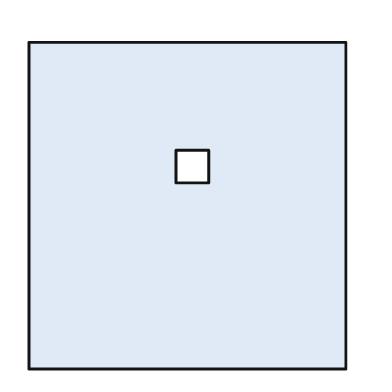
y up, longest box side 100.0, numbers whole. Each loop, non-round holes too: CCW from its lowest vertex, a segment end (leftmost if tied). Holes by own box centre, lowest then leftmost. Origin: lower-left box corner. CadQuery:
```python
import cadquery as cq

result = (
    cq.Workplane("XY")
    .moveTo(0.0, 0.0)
    .lineTo(97.0, 0.0)
    .lineTo(97.0, 100.0)
    .lineTo(0.0, 100.0)
    .close()
    .moveTo(45.0, 57.0)
    .lineTo(55.0, 57.0)
    .lineTo(55.0, 67.0)
    .lineTo(45.0, 67.0)
    .close()
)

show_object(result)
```